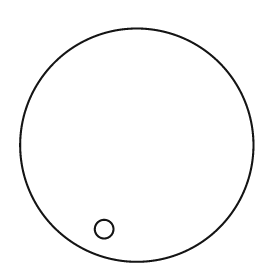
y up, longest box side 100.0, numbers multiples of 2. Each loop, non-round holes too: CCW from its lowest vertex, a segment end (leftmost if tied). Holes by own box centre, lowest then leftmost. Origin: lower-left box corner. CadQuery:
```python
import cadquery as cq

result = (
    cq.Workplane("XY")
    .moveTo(50.0, 50.0)
    .circle(50.0)
    .moveTo(36.0, 14.0)
    .circle(4.0)
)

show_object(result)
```